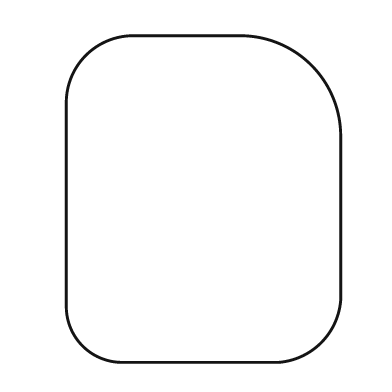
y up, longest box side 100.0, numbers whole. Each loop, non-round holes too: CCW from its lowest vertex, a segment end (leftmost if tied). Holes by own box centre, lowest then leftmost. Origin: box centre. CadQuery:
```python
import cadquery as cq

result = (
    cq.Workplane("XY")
    .moveTo(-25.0, -50.0)
    .lineTo(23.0, -50.0)
    .threePointArc((36.0, -44.0), (42.0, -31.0))
    .lineTo(42.0, 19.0)
    .threePointArc((33.0, 41.0), (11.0, 50.0))
    .lineTo(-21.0, 50.0)
    .threePointArc((-36.0, 44.0), (-42.0, 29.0))
    .lineTo(-42.0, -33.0)
    .threePointArc((-37.0, -45.0), (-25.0, -50.0))
    .close()
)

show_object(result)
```